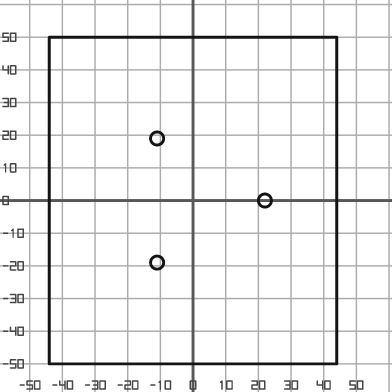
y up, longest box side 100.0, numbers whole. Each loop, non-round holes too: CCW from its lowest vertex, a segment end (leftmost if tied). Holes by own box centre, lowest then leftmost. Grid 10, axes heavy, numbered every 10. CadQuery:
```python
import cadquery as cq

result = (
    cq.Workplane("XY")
    .moveTo(-44.0, -50.0)
    .lineTo(44.0, -50.0)
    .lineTo(44.0, 50.0)
    .lineTo(-44.0, 50.0)
    .close()
    .moveTo(-11.0, -19.0)
    .circle(2.0)
    .moveTo(22.0, 0.0)
    .circle(2.0)
    .moveTo(-11.0, 19.0)
    .circle(2.0)
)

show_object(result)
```